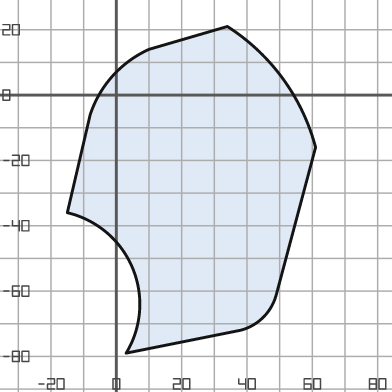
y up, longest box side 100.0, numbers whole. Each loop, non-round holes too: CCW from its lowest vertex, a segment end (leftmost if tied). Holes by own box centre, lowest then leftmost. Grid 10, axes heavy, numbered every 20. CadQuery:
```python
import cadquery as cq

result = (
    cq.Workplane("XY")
    .moveTo(3.0, -79.0)
    .lineTo(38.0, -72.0)
    .threePointArc((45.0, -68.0), (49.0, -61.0))
    .lineTo(61.0, -16.0)
    .threePointArc((51.0, 5.0), (34.0, 21.0))
    .lineTo(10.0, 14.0)
    .threePointArc((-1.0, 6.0), (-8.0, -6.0))
    .lineTo(-15.0, -36.0)
    .threePointArc((5.0, -53.0), (3.0, -79.0))
    .close()
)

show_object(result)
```